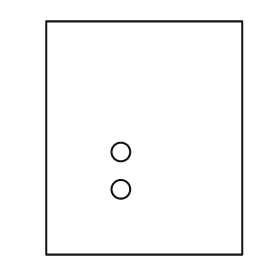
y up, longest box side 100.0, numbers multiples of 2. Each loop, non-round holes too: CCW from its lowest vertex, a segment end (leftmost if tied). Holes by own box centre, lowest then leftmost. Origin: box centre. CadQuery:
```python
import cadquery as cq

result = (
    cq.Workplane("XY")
    .moveTo(-42.0, -50.0)
    .lineTo(42.0, -50.0)
    .lineTo(42.0, 50.0)
    .lineTo(-42.0, 50.0)
    .close()
    .moveTo(-10.0, -22.0)
    .circle(4.0)
    .moveTo(-10.0, -6.0)
    .circle(4.0)
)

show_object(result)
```